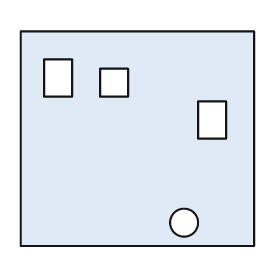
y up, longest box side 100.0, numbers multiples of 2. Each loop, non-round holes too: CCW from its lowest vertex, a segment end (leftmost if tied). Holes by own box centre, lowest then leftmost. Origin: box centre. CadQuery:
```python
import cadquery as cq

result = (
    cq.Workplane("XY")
    .moveTo(-50.0, -46.0)
    .lineTo(50.0, -46.0)
    .lineTo(50.0, 46.0)
    .lineTo(-50.0, 46.0)
    .close()
    .moveTo(20.0, -36.0)
    .circle(6.0)
    .moveTo(26.0, 0.0)
    .lineTo(38.0, 0.0)
    .lineTo(38.0, 16.0)
    .lineTo(26.0, 16.0)
    .close()
    .moveTo(-16.0, 18.0)
    .lineTo(-4.0, 18.0)
    .lineTo(-4.0, 30.0)
    .lineTo(-16.0, 30.0)
    .close()
    .moveTo(-40.0, 18.0)
    .lineTo(-28.0, 18.0)
    .lineTo(-28.0, 34.0)
    .lineTo(-40.0, 34.0)
    .close()
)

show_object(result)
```